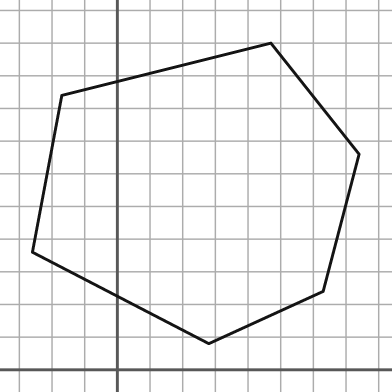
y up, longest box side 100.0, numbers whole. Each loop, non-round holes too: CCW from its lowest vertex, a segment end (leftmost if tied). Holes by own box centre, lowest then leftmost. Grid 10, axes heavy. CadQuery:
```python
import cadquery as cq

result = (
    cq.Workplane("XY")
    .moveTo(28.0, 8.0)
    .lineTo(63.0, 24.0)
    .lineTo(74.0, 66.0)
    .lineTo(47.0, 100.0)
    .lineTo(-17.0, 84.0)
    .lineTo(-26.0, 36.0)
    .close()
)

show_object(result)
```